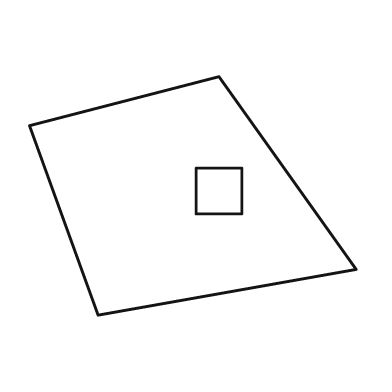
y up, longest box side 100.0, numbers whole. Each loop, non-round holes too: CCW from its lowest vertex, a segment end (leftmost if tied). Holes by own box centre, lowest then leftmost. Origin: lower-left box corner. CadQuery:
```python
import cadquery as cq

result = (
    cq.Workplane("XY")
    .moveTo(21.0, 0.0)
    .lineTo(100.0, 14.0)
    .lineTo(58.0, 73.0)
    .lineTo(0.0, 58.0)
    .close()
    .moveTo(51.0, 31.0)
    .lineTo(65.0, 31.0)
    .lineTo(65.0, 45.0)
    .lineTo(51.0, 45.0)
    .close()
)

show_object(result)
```